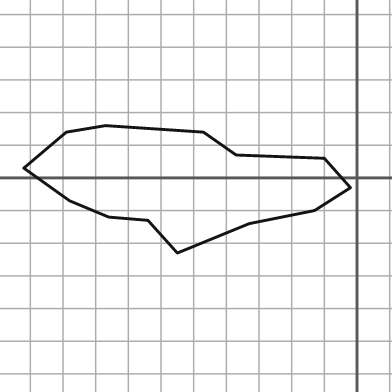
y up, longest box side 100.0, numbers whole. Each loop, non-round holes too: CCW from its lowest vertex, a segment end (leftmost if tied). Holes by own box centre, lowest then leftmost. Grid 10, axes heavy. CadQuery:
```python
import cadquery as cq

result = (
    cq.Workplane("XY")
    .moveTo(-55.0, -23.0)
    .lineTo(-33.0, -14.0)
    .lineTo(-13.0, -10.0)
    .lineTo(-2.0, -3.0)
    .lineTo(-10.0, 6.0)
    .lineTo(-37.0, 7.0)
    .lineTo(-47.0, 14.0)
    .lineTo(-77.0, 16.0)
    .lineTo(-89.0, 14.0)
    .lineTo(-102.0, 3.0)
    .lineTo(-88.0, -7.0)
    .lineTo(-76.0, -12.0)
    .lineTo(-64.0, -13.0)
    .close()
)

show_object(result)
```